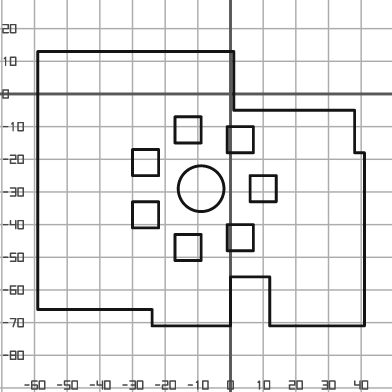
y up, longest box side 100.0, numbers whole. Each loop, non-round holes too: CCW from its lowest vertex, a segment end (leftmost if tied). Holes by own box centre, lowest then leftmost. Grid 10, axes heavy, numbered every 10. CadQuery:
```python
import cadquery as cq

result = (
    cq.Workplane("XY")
    .moveTo(-24.0, -71.0)
    .lineTo(0.0, -71.0)
    .lineTo(0.0, -56.0)
    .lineTo(12.0, -56.0)
    .lineTo(12.0, -71.0)
    .lineTo(41.0, -71.0)
    .lineTo(41.0, -18.0)
    .lineTo(38.0, -18.0)
    .lineTo(38.0, -5.0)
    .lineTo(1.0, -5.0)
    .lineTo(1.0, 13.0)
    .lineTo(-59.0, 13.0)
    .lineTo(-59.0, -66.0)
    .lineTo(-24.0, -66.0)
    .close()
    .moveTo(-17.0, -51.0)
    .lineTo(-9.0, -51.0)
    .lineTo(-9.0, -43.0)
    .lineTo(-17.0, -43.0)
    .close()
    .moveTo(-1.0, -48.0)
    .lineTo(7.0, -48.0)
    .lineTo(7.0, -40.0)
    .lineTo(-1.0, -40.0)
    .close()
    .moveTo(-30.0, -41.0)
    .lineTo(-22.0, -41.0)
    .lineTo(-22.0, -33.0)
    .lineTo(-30.0, -33.0)
    .close()
    .moveTo(-9.0, -29.0)
    .circle(7.0)
    .moveTo(6.0, -33.0)
    .lineTo(14.0, -33.0)
    .lineTo(14.0, -25.0)
    .lineTo(6.0, -25.0)
    .close()
    .moveTo(-30.0, -25.0)
    .lineTo(-22.0, -25.0)
    .lineTo(-22.0, -17.0)
    .lineTo(-30.0, -17.0)
    .close()
    .moveTo(-1.0, -18.0)
    .lineTo(7.0, -18.0)
    .lineTo(7.0, -10.0)
    .lineTo(-1.0, -10.0)
    .close()
    .moveTo(-17.0, -15.0)
    .lineTo(-9.0, -15.0)
    .lineTo(-9.0, -7.0)
    .lineTo(-17.0, -7.0)
    .close()
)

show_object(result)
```